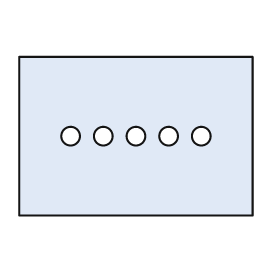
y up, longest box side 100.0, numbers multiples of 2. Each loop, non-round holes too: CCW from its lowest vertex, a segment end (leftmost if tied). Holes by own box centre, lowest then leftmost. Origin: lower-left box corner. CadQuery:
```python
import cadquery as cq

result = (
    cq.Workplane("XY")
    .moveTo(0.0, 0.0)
    .lineTo(100.0, 0.0)
    .lineTo(100.0, 68.0)
    .lineTo(0.0, 68.0)
    .close()
    .moveTo(22.0, 34.0)
    .circle(4.0)
    .moveTo(36.0, 34.0)
    .circle(4.0)
    .moveTo(50.0, 34.0)
    .circle(4.0)
    .moveTo(64.0, 34.0)
    .circle(4.0)
    .moveTo(78.0, 34.0)
    .circle(4.0)
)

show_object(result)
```